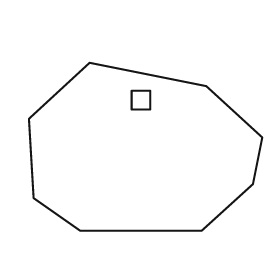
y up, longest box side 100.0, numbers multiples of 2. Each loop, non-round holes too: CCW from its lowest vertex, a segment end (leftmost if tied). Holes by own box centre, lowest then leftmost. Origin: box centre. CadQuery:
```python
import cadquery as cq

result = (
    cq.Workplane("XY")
    .moveTo(-28.0, -36.0)
    .lineTo(24.0, -36.0)
    .lineTo(46.0, -16.0)
    .lineTo(50.0, 4.0)
    .lineTo(26.0, 26.0)
    .lineTo(-24.0, 36.0)
    .lineTo(-50.0, 12.0)
    .lineTo(-48.0, -22.0)
    .close()
    .moveTo(-6.0, 16.0)
    .lineTo(2.0, 16.0)
    .lineTo(2.0, 24.0)
    .lineTo(-6.0, 24.0)
    .close()
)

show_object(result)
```